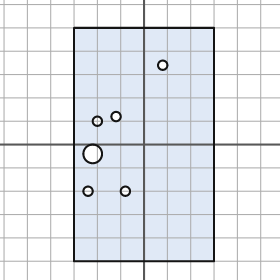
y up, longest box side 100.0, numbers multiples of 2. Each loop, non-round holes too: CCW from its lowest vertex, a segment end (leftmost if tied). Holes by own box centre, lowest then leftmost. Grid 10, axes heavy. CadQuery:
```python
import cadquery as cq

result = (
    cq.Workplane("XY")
    .moveTo(-30.0, -50.0)
    .lineTo(30.0, -50.0)
    .lineTo(30.0, 50.0)
    .lineTo(-30.0, 50.0)
    .close()
    .moveTo(-24.0, -20.0)
    .circle(2.0)
    .moveTo(-8.0, -20.0)
    .circle(2.0)
    .moveTo(-22.0, -4.0)
    .circle(4.0)
    .moveTo(-20.0, 10.0)
    .circle(2.0)
    .moveTo(-12.0, 12.0)
    .circle(2.0)
    .moveTo(8.0, 34.0)
    .circle(2.0)
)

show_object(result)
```